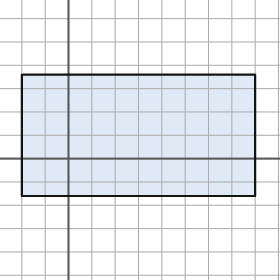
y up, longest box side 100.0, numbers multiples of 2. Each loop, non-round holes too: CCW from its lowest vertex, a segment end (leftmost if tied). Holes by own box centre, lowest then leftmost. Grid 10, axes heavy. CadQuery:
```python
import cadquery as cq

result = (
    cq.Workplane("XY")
    .moveTo(-20.0, -16.0)
    .lineTo(80.0, -16.0)
    .lineTo(80.0, 36.0)
    .lineTo(-20.0, 36.0)
    .close()
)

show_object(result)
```